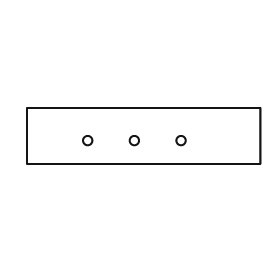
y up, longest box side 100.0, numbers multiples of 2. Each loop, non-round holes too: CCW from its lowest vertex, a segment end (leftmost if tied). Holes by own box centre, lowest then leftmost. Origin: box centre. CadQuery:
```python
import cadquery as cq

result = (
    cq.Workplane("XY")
    .moveTo(-50.0, -12.0)
    .lineTo(50.0, -12.0)
    .lineTo(50.0, 12.0)
    .lineTo(-50.0, 12.0)
    .close()
    .moveTo(-24.0, -2.0)
    .circle(2.0)
    .moveTo(-4.0, -2.0)
    .circle(2.0)
    .moveTo(16.0, -2.0)
    .circle(2.0)
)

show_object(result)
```